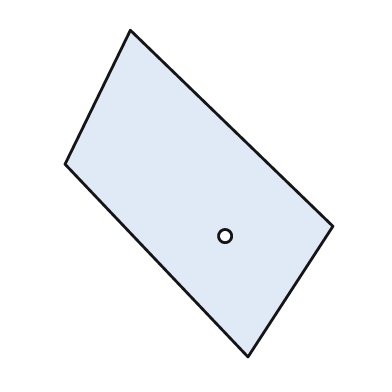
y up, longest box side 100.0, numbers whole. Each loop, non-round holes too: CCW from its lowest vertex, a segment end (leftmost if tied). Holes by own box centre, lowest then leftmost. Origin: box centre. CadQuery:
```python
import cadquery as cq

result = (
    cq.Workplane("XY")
    .moveTo(15.0, -50.0)
    .lineTo(41.0, -10.0)
    .lineTo(-21.0, 50.0)
    .lineTo(-41.0, 9.0)
    .close()
    .moveTo(8.0, -13.0)
    .circle(2.0)
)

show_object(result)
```